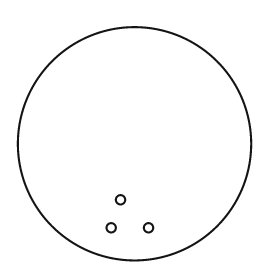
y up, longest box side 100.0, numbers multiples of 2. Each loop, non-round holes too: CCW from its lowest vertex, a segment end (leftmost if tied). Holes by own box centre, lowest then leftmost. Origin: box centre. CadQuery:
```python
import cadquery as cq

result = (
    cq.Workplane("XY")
    .moveTo(0.0, 0.0)
    .circle(50.0)
    .moveTo(-10.0, -36.0)
    .circle(2.0)
    .moveTo(6.0, -36.0)
    .circle(2.0)
    .moveTo(-6.0, -24.0)
    .circle(2.0)
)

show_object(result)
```